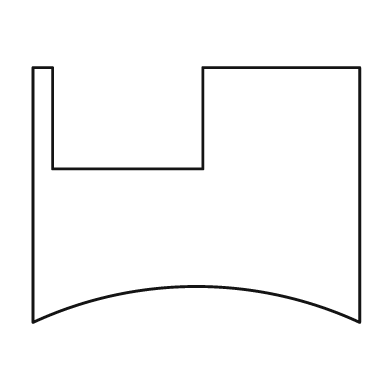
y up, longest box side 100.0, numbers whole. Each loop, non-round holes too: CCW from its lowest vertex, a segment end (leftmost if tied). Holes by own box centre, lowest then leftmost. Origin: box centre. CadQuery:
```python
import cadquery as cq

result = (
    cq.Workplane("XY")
    .moveTo(-50.0, -39.0)
    .threePointArc((0.0, -28.0), (50.0, -39.0))
    .lineTo(50.0, 39.0)
    .lineTo(2.0, 39.0)
    .lineTo(2.0, 8.0)
    .lineTo(-44.0, 8.0)
    .lineTo(-44.0, 39.0)
    .lineTo(-50.0, 39.0)
    .close()
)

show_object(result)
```